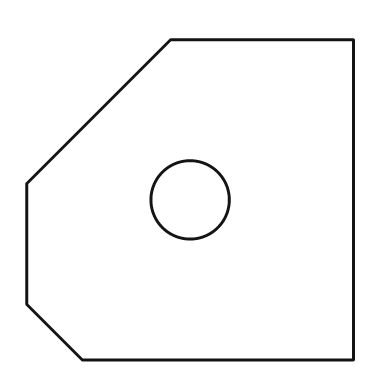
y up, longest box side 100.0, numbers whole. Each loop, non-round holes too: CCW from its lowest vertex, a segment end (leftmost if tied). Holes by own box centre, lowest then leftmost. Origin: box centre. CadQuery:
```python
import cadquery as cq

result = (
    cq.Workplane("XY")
    .moveTo(-33.0, -49.0)
    .lineTo(50.0, -49.0)
    .lineTo(50.0, 49.0)
    .lineTo(-6.0, 49.0)
    .lineTo(-50.0, 5.0)
    .lineTo(-50.0, -32.0)
    .close()
    .moveTo(0.0, 0.0)
    .circle(12.0)
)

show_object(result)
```